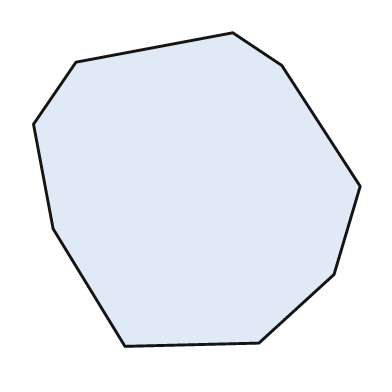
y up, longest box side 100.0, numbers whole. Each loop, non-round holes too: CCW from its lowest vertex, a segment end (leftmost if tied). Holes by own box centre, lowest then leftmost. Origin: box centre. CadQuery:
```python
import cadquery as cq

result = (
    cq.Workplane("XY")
    .moveTo(-22.0, -48.0)
    .lineTo(19.0, -47.0)
    .lineTo(42.0, -26.0)
    .lineTo(50.0, 1.0)
    .lineTo(26.0, 38.0)
    .lineTo(11.0, 48.0)
    .lineTo(-37.0, 39.0)
    .lineTo(-50.0, 20.0)
    .lineTo(-44.0, -12.0)
    .close()
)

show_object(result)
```